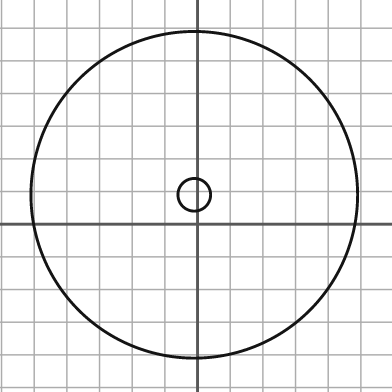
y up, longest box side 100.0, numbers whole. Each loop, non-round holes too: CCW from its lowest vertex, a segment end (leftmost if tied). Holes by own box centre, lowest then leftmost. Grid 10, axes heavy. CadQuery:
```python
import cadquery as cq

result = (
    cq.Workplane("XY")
    .moveTo(-1.0, 9.0)
    .circle(50.0)
    .moveTo(-1.0, 9.0)
    .circle(5.0)
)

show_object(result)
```